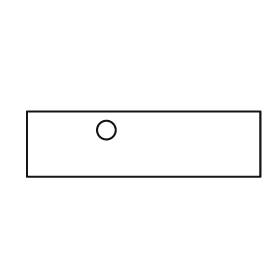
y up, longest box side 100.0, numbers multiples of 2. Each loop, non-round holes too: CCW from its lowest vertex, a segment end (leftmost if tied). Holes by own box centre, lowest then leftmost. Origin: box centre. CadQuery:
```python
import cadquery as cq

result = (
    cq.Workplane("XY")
    .moveTo(-50.0, -14.0)
    .lineTo(50.0, -14.0)
    .lineTo(50.0, 14.0)
    .lineTo(-50.0, 14.0)
    .close()
    .moveTo(-16.0, 6.0)
    .circle(4.0)
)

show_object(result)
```